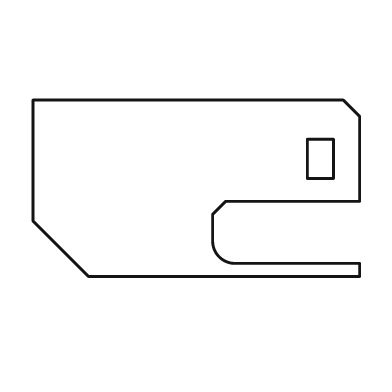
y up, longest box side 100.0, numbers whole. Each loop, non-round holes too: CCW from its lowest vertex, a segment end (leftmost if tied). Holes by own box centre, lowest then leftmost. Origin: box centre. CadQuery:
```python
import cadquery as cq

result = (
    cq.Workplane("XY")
    .moveTo(-33.0, -27.0)
    .lineTo(50.0, -27.0)
    .lineTo(50.0, -23.0)
    .lineTo(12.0, -23.0)
    .threePointArc((7.0, -21.0), (5.0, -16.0))
    .lineTo(5.0, -8.0)
    .lineTo(9.0, -4.0)
    .lineTo(50.0, -4.0)
    .lineTo(50.0, 22.0)
    .lineTo(45.0, 27.0)
    .lineTo(-50.0, 27.0)
    .lineTo(-50.0, -10.0)
    .close()
    .moveTo(34.0, 3.0)
    .lineTo(42.0, 3.0)
    .lineTo(42.0, 15.0)
    .lineTo(34.0, 15.0)
    .close()
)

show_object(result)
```